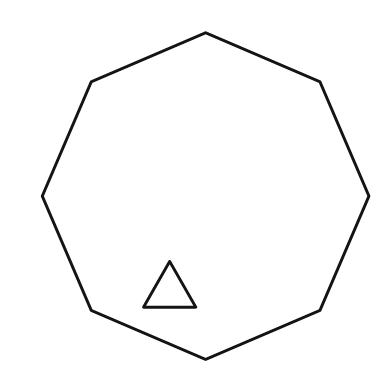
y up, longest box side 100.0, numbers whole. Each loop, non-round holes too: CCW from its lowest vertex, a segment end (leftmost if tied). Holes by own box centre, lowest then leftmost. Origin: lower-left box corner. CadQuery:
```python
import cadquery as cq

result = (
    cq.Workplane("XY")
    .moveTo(50.0, 0.0)
    .lineTo(85.0, 15.0)
    .lineTo(100.0, 50.0)
    .lineTo(85.0, 85.0)
    .lineTo(50.0, 100.0)
    .lineTo(15.0, 85.0)
    .lineTo(0.0, 50.0)
    .lineTo(15.0, 15.0)
    .close()
    .moveTo(31.0, 16.0)
    .lineTo(47.0, 16.0)
    .lineTo(39.0, 30.0)
    .close()
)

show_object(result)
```